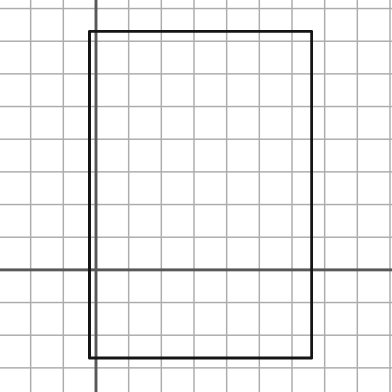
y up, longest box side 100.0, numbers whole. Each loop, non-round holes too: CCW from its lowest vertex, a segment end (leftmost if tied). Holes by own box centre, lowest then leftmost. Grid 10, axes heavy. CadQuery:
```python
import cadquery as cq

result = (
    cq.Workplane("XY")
    .moveTo(-2.0, -27.0)
    .lineTo(66.0, -27.0)
    .lineTo(66.0, 73.0)
    .lineTo(-2.0, 73.0)
    .close()
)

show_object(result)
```